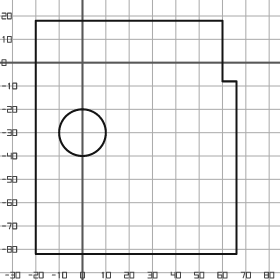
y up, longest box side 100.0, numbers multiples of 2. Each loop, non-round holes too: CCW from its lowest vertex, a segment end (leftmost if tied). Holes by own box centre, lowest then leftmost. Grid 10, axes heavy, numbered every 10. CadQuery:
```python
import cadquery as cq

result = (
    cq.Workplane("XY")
    .moveTo(-20.0, -82.0)
    .lineTo(66.0, -82.0)
    .lineTo(66.0, -8.0)
    .lineTo(60.0, -8.0)
    .lineTo(60.0, 18.0)
    .lineTo(-20.0, 18.0)
    .close()
    .moveTo(0.0, -30.0)
    .circle(10.0)
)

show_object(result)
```